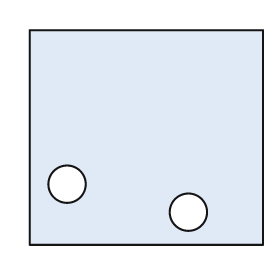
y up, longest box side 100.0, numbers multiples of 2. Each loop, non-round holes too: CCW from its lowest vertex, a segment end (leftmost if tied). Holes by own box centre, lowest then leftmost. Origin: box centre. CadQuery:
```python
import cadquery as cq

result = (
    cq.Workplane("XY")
    .moveTo(-50.0, -46.0)
    .lineTo(50.0, -46.0)
    .lineTo(50.0, 46.0)
    .lineTo(-50.0, 46.0)
    .close()
    .moveTo(18.0, -32.0)
    .circle(8.0)
    .moveTo(-34.0, -20.0)
    .circle(8.0)
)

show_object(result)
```